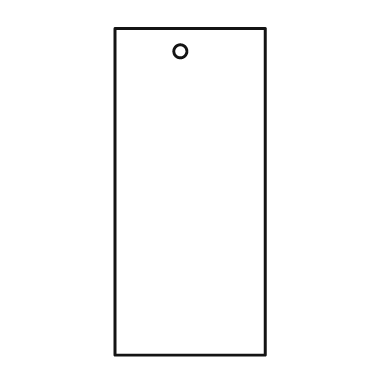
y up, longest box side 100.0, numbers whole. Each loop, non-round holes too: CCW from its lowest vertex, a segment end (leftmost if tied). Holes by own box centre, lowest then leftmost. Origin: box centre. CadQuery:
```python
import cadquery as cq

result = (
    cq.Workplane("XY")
    .moveTo(-23.0, -50.0)
    .lineTo(23.0, -50.0)
    .lineTo(23.0, 50.0)
    .lineTo(-23.0, 50.0)
    .close()
    .moveTo(-3.0, 43.0)
    .circle(2.0)
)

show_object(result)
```